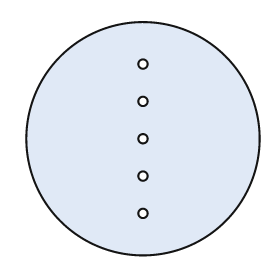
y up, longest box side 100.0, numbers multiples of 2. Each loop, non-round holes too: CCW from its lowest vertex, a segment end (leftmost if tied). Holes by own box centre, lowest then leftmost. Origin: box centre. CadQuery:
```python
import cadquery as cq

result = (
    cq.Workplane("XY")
    .moveTo(0.0, 0.0)
    .circle(50.0)
    .moveTo(0.0, -32.0)
    .circle(2.0)
    .moveTo(0.0, -16.0)
    .circle(2.0)
    .moveTo(0.0, 0.0)
    .circle(2.0)
    .moveTo(0.0, 16.0)
    .circle(2.0)
    .moveTo(0.0, 32.0)
    .circle(2.0)
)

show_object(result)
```